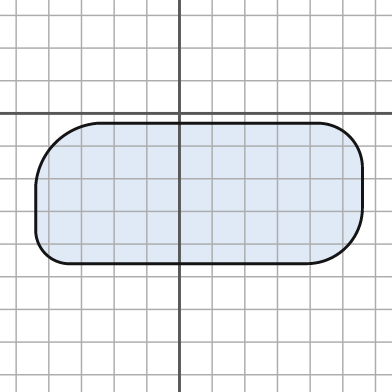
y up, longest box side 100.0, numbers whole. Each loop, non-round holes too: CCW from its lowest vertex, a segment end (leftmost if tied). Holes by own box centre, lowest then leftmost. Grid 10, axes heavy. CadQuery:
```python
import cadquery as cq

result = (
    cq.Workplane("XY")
    .moveTo(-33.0, -46.0)
    .lineTo(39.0, -46.0)
    .threePointArc((51.0, -41.0), (56.0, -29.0))
    .lineTo(56.0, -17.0)
    .threePointArc((52.0, -7.0), (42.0, -3.0))
    .lineTo(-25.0, -3.0)
    .threePointArc((-38.0, -9.0), (-44.0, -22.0))
    .lineTo(-44.0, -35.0)
    .threePointArc((-41.0, -43.0), (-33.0, -46.0))
    .close()
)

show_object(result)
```